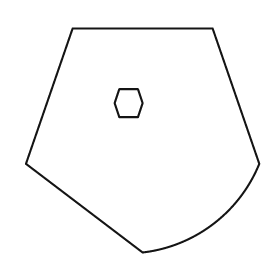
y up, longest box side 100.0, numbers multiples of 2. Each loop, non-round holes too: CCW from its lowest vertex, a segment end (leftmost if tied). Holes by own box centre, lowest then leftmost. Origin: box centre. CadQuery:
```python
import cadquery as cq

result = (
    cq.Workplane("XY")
    .moveTo(0.0, -48.0)
    .threePointArc((30.0, -36.0), (50.0, -10.0))
    .lineTo(30.0, 48.0)
    .lineTo(-30.0, 48.0)
    .lineTo(-50.0, -10.0)
    .close()
    .moveTo(-10.0, 10.0)
    .lineTo(-2.0, 10.0)
    .lineTo(0.0, 16.0)
    .lineTo(-2.0, 22.0)
    .lineTo(-10.0, 22.0)
    .lineTo(-12.0, 16.0)
    .close()
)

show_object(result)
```